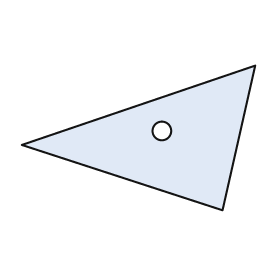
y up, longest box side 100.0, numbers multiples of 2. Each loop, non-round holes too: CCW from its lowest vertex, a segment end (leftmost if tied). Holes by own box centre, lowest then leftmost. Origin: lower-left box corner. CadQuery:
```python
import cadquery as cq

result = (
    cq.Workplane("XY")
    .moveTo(86.0, 0.0)
    .lineTo(100.0, 62.0)
    .lineTo(0.0, 28.0)
    .close()
    .moveTo(60.0, 34.0)
    .circle(4.0)
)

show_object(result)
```